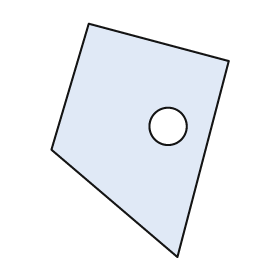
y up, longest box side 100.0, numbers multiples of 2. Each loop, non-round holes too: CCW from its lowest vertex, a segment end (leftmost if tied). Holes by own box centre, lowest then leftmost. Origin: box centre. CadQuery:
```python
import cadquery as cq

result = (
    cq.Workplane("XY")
    .moveTo(16.0, -50.0)
    .lineTo(38.0, 34.0)
    .lineTo(-22.0, 50.0)
    .lineTo(-38.0, -4.0)
    .close()
    .moveTo(12.0, 6.0)
    .circle(8.0)
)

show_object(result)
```